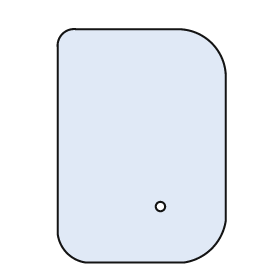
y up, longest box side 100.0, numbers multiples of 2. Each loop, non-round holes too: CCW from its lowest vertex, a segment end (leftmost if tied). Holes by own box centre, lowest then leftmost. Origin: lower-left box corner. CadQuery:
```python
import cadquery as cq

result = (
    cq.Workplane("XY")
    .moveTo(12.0, 0.0)
    .lineTo(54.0, 0.0)
    .threePointArc((66.0, 6.0), (72.0, 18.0))
    .lineTo(72.0, 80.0)
    .threePointArc((66.0, 94.0), (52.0, 100.0))
    .lineTo(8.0, 100.0)
    .threePointArc((2.0, 98.0), (0.0, 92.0))
    .lineTo(0.0, 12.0)
    .threePointArc((4.0, 4.0), (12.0, 0.0))
    .close()
    .moveTo(44.0, 24.0)
    .circle(2.0)
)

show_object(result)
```